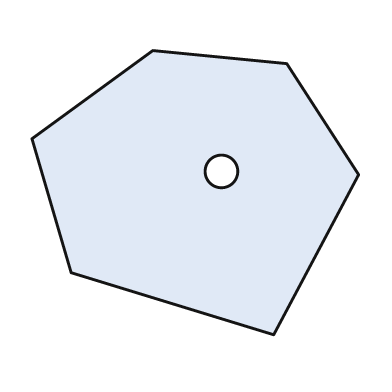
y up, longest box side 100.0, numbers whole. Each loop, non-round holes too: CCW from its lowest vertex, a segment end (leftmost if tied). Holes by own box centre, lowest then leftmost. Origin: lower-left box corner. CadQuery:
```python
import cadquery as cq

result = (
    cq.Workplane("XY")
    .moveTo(74.0, 0.0)
    .lineTo(100.0, 49.0)
    .lineTo(78.0, 83.0)
    .lineTo(37.0, 87.0)
    .lineTo(0.0, 60.0)
    .lineTo(12.0, 19.0)
    .close()
    .moveTo(58.0, 50.0)
    .circle(5.0)
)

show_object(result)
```